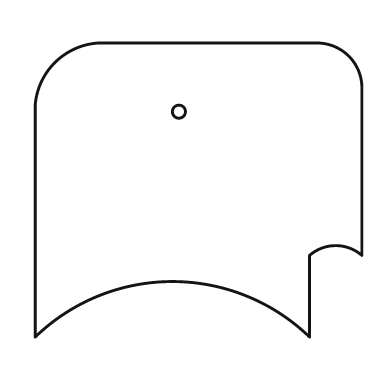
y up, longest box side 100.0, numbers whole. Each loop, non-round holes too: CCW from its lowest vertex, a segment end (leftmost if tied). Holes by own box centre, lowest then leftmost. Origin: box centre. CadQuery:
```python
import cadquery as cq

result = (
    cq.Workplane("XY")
    .moveTo(-50.0, -45.0)
    .threePointArc((-8.0, -28.0), (34.0, -45.0))
    .lineTo(34.0, -20.0)
    .threePointArc((42.0, -17.0), (50.0, -20.0))
    .lineTo(50.0, 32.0)
    .threePointArc((46.0, 41.0), (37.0, 45.0))
    .lineTo(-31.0, 45.0)
    .threePointArc((-44.0, 39.0), (-50.0, 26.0))
    .close()
    .moveTo(-6.0, 24.0)
    .circle(2.0)
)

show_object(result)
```